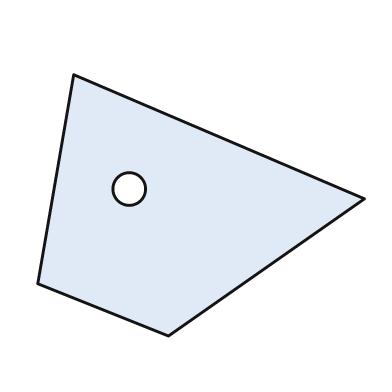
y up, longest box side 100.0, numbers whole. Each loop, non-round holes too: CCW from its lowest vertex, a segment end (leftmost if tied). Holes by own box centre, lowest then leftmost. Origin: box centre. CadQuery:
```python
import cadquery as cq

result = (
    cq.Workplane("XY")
    .moveTo(-10.0, -40.0)
    .lineTo(50.0, 2.0)
    .lineTo(-39.0, 40.0)
    .lineTo(-50.0, -24.0)
    .close()
    .moveTo(-22.0, 5.0)
    .circle(5.0)
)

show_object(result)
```